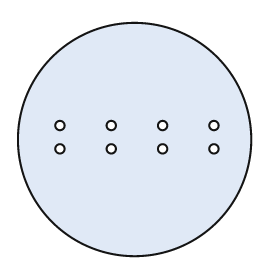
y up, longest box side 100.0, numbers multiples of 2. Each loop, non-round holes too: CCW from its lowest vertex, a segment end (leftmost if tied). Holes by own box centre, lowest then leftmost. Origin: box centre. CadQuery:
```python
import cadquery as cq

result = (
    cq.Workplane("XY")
    .moveTo(0.0, 0.0)
    .circle(50.0)
    .moveTo(-32.0, -4.0)
    .circle(2.0)
    .moveTo(-10.0, -4.0)
    .circle(2.0)
    .moveTo(12.0, -4.0)
    .circle(2.0)
    .moveTo(34.0, -4.0)
    .circle(2.0)
    .moveTo(-32.0, 6.0)
    .circle(2.0)
    .moveTo(-10.0, 6.0)
    .circle(2.0)
    .moveTo(12.0, 6.0)
    .circle(2.0)
    .moveTo(34.0, 6.0)
    .circle(2.0)
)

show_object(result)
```